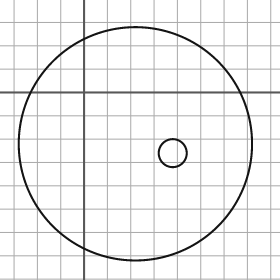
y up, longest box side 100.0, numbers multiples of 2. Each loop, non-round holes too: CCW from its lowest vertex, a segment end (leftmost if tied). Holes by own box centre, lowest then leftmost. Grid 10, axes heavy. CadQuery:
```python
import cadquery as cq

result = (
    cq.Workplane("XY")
    .moveTo(22.0, -22.0)
    .circle(50.0)
    .moveTo(38.0, -26.0)
    .circle(6.0)
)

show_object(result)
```